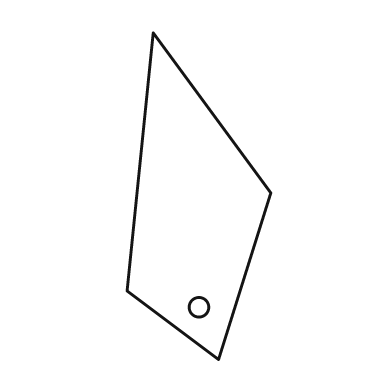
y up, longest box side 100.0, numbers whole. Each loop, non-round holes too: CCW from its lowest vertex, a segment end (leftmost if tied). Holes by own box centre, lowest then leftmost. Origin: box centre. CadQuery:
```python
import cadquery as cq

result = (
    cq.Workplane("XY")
    .moveTo(6.0, -50.0)
    .lineTo(22.0, 1.0)
    .lineTo(-14.0, 50.0)
    .lineTo(-22.0, -29.0)
    .close()
    .moveTo(0.0, -34.0)
    .circle(3.0)
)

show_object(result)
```